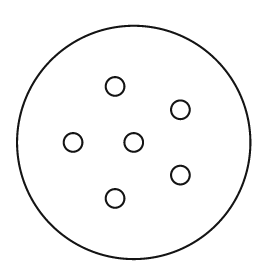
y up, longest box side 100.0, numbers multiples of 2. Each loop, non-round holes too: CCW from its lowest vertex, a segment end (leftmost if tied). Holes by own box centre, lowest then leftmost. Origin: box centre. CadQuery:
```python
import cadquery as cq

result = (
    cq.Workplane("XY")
    .moveTo(0.0, 0.0)
    .circle(50.0)
    .moveTo(-8.0, -24.0)
    .circle(4.0)
    .moveTo(20.0, -14.0)
    .circle(4.0)
    .moveTo(-26.0, 0.0)
    .circle(4.0)
    .moveTo(0.0, 0.0)
    .circle(4.0)
    .moveTo(20.0, 14.0)
    .circle(4.0)
    .moveTo(-8.0, 24.0)
    .circle(4.0)
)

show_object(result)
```